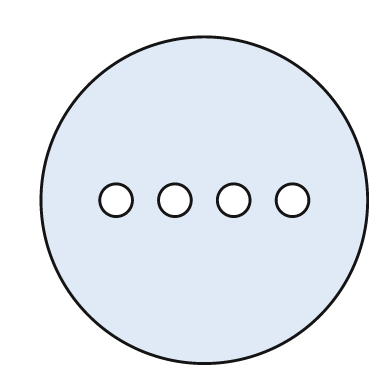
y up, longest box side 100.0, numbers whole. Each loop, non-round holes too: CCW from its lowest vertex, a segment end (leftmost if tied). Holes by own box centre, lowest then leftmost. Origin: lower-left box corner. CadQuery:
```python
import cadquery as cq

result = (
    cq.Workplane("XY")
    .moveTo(50.0, 50.0)
    .circle(50.0)
    .moveTo(23.0, 50.0)
    .circle(5.0)
    .moveTo(41.0, 50.0)
    .circle(5.0)
    .moveTo(59.0, 50.0)
    .circle(5.0)
    .moveTo(77.0, 50.0)
    .circle(5.0)
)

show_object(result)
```